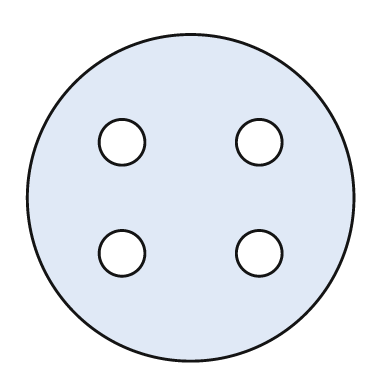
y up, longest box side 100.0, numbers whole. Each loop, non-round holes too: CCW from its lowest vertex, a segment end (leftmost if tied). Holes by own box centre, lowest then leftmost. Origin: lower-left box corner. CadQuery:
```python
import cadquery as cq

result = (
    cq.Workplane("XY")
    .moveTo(50.0, 50.0)
    .circle(50.0)
    .moveTo(29.0, 33.0)
    .circle(7.0)
    .moveTo(71.0, 33.0)
    .circle(7.0)
    .moveTo(29.0, 67.0)
    .circle(7.0)
    .moveTo(71.0, 67.0)
    .circle(7.0)
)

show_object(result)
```